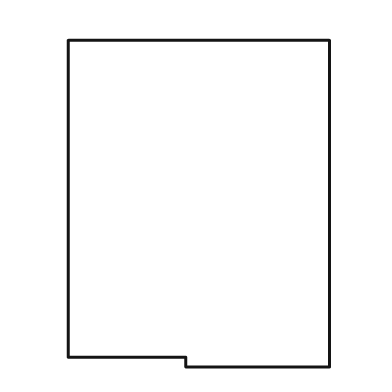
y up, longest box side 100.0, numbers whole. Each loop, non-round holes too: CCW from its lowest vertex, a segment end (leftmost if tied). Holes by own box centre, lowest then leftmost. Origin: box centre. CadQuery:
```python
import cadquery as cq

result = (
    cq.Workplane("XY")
    .moveTo(-4.0, -50.0)
    .lineTo(40.0, -50.0)
    .lineTo(40.0, 50.0)
    .lineTo(-40.0, 50.0)
    .lineTo(-40.0, -47.0)
    .lineTo(-4.0, -47.0)
    .close()
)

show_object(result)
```